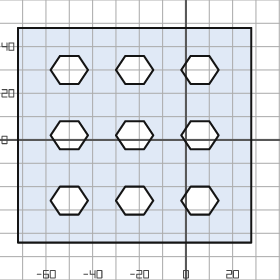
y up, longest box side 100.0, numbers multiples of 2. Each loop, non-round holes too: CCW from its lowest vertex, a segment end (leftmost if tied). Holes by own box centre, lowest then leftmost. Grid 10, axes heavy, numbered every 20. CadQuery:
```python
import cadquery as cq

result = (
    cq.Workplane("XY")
    .moveTo(-72.0, -44.0)
    .lineTo(28.0, -44.0)
    .lineTo(28.0, 48.0)
    .lineTo(-72.0, 48.0)
    .close()
    .moveTo(-54.0, -32.0)
    .lineTo(-46.0, -32.0)
    .lineTo(-42.0, -26.0)
    .lineTo(-46.0, -20.0)
    .lineTo(-54.0, -20.0)
    .lineTo(-58.0, -26.0)
    .close()
    .moveTo(-26.0, -32.0)
    .lineTo(-18.0, -32.0)
    .lineTo(-14.0, -26.0)
    .lineTo(-18.0, -20.0)
    .lineTo(-26.0, -20.0)
    .lineTo(-30.0, -26.0)
    .close()
    .moveTo(2.0, -32.0)
    .lineTo(10.0, -32.0)
    .lineTo(14.0, -26.0)
    .lineTo(10.0, -20.0)
    .lineTo(2.0, -20.0)
    .lineTo(-2.0, -26.0)
    .close()
    .moveTo(-54.0, -4.0)
    .lineTo(-46.0, -4.0)
    .lineTo(-42.0, 2.0)
    .lineTo(-46.0, 8.0)
    .lineTo(-54.0, 8.0)
    .lineTo(-58.0, 2.0)
    .close()
    .moveTo(-26.0, -4.0)
    .lineTo(-18.0, -4.0)
    .lineTo(-14.0, 2.0)
    .lineTo(-18.0, 8.0)
    .lineTo(-26.0, 8.0)
    .lineTo(-30.0, 2.0)
    .close()
    .moveTo(2.0, -4.0)
    .lineTo(10.0, -4.0)
    .lineTo(14.0, 2.0)
    .lineTo(10.0, 8.0)
    .lineTo(2.0, 8.0)
    .lineTo(-2.0, 2.0)
    .close()
    .moveTo(-54.0, 24.0)
    .lineTo(-46.0, 24.0)
    .lineTo(-42.0, 30.0)
    .lineTo(-46.0, 36.0)
    .lineTo(-54.0, 36.0)
    .lineTo(-58.0, 30.0)
    .close()
    .moveTo(-26.0, 24.0)
    .lineTo(-18.0, 24.0)
    .lineTo(-14.0, 30.0)
    .lineTo(-18.0, 36.0)
    .lineTo(-26.0, 36.0)
    .lineTo(-30.0, 30.0)
    .close()
    .moveTo(2.0, 24.0)
    .lineTo(10.0, 24.0)
    .lineTo(14.0, 30.0)
    .lineTo(10.0, 36.0)
    .lineTo(2.0, 36.0)
    .lineTo(-2.0, 30.0)
    .close()
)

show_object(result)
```